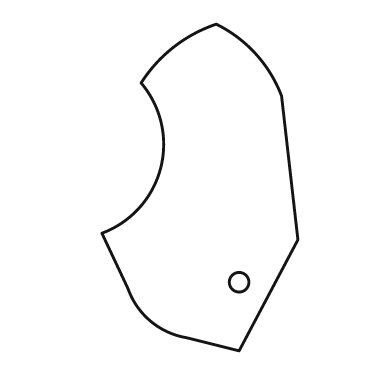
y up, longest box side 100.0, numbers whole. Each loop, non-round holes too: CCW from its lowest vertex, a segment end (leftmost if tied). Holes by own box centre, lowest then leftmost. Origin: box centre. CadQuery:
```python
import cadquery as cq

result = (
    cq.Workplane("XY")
    .moveTo(12.0, -50.0)
    .lineTo(30.0, -16.0)
    .lineTo(25.0, 28.0)
    .threePointArc((17.0, 41.0), (5.0, 50.0))
    .threePointArc((-8.0, 43.0), (-18.0, 32.0))
    .threePointArc((-12.0, 6.0), (-30.0, -14.0))
    .lineTo(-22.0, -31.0)
    .threePointArc((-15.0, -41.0), (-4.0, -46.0))
    .close()
    .moveTo(12.0, -29.0)
    .circle(3.0)
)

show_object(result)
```